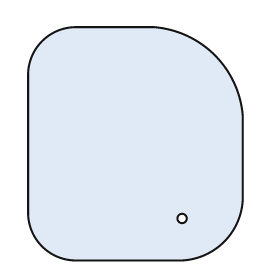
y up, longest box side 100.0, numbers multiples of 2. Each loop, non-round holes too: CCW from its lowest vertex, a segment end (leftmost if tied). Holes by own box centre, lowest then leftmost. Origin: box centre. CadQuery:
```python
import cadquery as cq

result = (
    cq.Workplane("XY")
    .moveTo(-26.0, -50.0)
    .lineTo(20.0, -50.0)
    .threePointArc((38.0, -42.0), (46.0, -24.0))
    .lineTo(46.0, 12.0)
    .threePointArc((34.0, 38.0), (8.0, 50.0))
    .lineTo(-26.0, 50.0)
    .threePointArc((-40.0, 44.0), (-46.0, 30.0))
    .lineTo(-46.0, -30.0)
    .threePointArc((-40.0, -44.0), (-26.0, -50.0))
    .close()
    .moveTo(20.0, -32.0)
    .circle(2.0)
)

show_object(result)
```